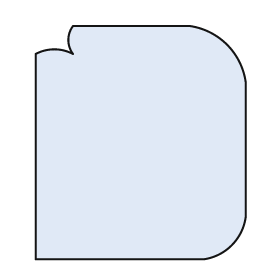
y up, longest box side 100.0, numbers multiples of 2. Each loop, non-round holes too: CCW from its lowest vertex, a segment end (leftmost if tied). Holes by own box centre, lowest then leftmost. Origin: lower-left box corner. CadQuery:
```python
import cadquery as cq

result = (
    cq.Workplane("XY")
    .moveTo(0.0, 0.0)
    .lineTo(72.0, 0.0)
    .threePointArc((84.0, 6.0), (90.0, 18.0))
    .lineTo(90.0, 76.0)
    .threePointArc((82.0, 92.0), (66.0, 100.0))
    .lineTo(16.0, 100.0)
    .threePointArc((14.0, 94.0), (16.0, 88.0))
    .threePointArc((8.0, 90.0), (0.0, 88.0))
    .close()
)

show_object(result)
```